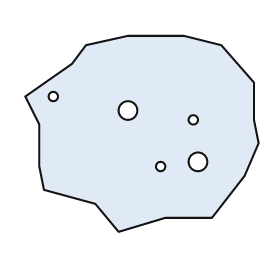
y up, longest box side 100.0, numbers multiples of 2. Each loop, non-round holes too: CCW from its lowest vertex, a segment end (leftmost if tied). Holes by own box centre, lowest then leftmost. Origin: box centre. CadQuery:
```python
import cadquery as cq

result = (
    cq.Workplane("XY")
    .moveTo(-10.0, -42.0)
    .lineTo(10.0, -36.0)
    .lineTo(30.0, -36.0)
    .lineTo(44.0, -18.0)
    .lineTo(50.0, -4.0)
    .lineTo(48.0, 6.0)
    .lineTo(48.0, 22.0)
    .lineTo(34.0, 38.0)
    .lineTo(18.0, 42.0)
    .lineTo(-6.0, 42.0)
    .lineTo(-24.0, 38.0)
    .lineTo(-30.0, 30.0)
    .lineTo(-50.0, 16.0)
    .lineTo(-44.0, 4.0)
    .lineTo(-44.0, -14.0)
    .lineTo(-42.0, -24.0)
    .lineTo(-20.0, -30.0)
    .close()
    .moveTo(8.0, -14.0)
    .circle(2.0)
    .moveTo(24.0, -12.0)
    .circle(4.0)
    .moveTo(22.0, 6.0)
    .circle(2.0)
    .moveTo(-6.0, 10.0)
    .circle(4.0)
    .moveTo(-38.0, 16.0)
    .circle(2.0)
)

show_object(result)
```